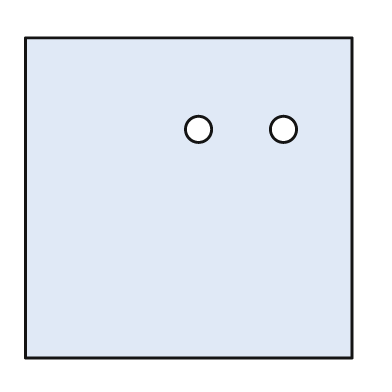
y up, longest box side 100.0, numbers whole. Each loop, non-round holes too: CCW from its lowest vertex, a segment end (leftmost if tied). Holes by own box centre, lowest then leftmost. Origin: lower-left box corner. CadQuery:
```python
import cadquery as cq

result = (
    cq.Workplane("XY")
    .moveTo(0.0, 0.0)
    .lineTo(100.0, 0.0)
    .lineTo(100.0, 98.0)
    .lineTo(0.0, 98.0)
    .close()
    .moveTo(53.0, 70.0)
    .circle(4.0)
    .moveTo(79.0, 70.0)
    .circle(4.0)
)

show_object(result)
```